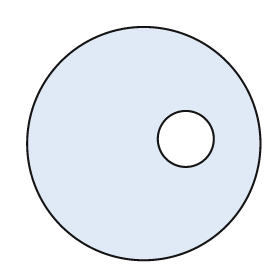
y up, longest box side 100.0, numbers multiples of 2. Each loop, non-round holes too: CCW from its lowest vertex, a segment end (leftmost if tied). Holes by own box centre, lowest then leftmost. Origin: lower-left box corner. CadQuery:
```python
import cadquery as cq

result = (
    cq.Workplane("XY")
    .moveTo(50.0, 50.0)
    .circle(50.0)
    .moveTo(68.0, 52.0)
    .circle(12.0)
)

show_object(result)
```